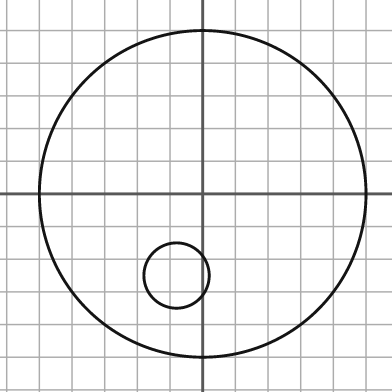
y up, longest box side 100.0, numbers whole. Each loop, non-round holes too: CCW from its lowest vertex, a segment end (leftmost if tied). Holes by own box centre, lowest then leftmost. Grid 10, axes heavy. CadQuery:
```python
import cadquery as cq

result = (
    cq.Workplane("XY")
    .moveTo(0.0, 0.0)
    .circle(50.0)
    .moveTo(-8.0, -25.0)
    .circle(10.0)
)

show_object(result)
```